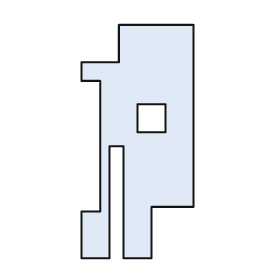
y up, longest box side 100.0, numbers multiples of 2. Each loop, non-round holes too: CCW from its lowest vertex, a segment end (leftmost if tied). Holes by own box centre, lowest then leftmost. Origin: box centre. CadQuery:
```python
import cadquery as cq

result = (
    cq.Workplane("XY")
    .moveTo(-24.0, -50.0)
    .lineTo(-12.0, -50.0)
    .lineTo(-12.0, -2.0)
    .lineTo(-6.0, -2.0)
    .lineTo(-6.0, -50.0)
    .lineTo(6.0, -50.0)
    .lineTo(6.0, -28.0)
    .lineTo(24.0, -28.0)
    .lineTo(24.0, 50.0)
    .lineTo(-8.0, 50.0)
    .lineTo(-8.0, 34.0)
    .lineTo(-24.0, 34.0)
    .lineTo(-24.0, 26.0)
    .lineTo(-16.0, 26.0)
    .lineTo(-16.0, -30.0)
    .lineTo(-24.0, -30.0)
    .close()
    .moveTo(0.0, 4.0)
    .lineTo(12.0, 4.0)
    .lineTo(12.0, 16.0)
    .lineTo(0.0, 16.0)
    .close()
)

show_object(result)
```